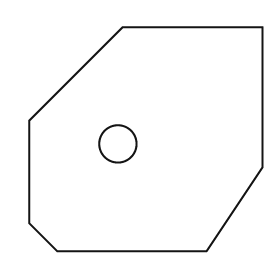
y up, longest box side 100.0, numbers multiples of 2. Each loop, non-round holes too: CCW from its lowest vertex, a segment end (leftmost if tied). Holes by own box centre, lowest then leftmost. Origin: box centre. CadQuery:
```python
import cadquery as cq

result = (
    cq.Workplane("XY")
    .moveTo(-38.0, -48.0)
    .lineTo(26.0, -48.0)
    .lineTo(50.0, -12.0)
    .lineTo(50.0, 48.0)
    .lineTo(-10.0, 48.0)
    .lineTo(-50.0, 8.0)
    .lineTo(-50.0, -36.0)
    .close()
    .moveTo(-12.0, -2.0)
    .circle(8.0)
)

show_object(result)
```